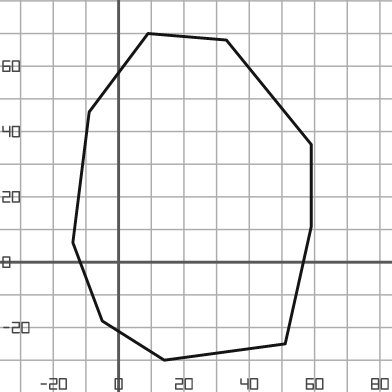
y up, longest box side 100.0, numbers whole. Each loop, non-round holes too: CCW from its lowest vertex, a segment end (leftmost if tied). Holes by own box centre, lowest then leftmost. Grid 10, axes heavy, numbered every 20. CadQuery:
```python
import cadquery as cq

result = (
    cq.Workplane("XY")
    .moveTo(14.0, -30.0)
    .lineTo(51.0, -25.0)
    .lineTo(59.0, 11.0)
    .lineTo(59.0, 36.0)
    .lineTo(33.0, 68.0)
    .lineTo(9.0, 70.0)
    .lineTo(-9.0, 46.0)
    .lineTo(-14.0, 6.0)
    .lineTo(-5.0, -18.0)
    .close()
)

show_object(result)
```